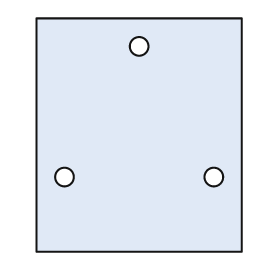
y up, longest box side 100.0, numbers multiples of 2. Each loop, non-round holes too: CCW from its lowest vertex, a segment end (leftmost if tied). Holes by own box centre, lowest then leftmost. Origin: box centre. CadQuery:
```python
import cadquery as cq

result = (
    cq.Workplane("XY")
    .moveTo(-44.0, -50.0)
    .lineTo(44.0, -50.0)
    .lineTo(44.0, 50.0)
    .lineTo(-44.0, 50.0)
    .close()
    .moveTo(-32.0, -18.0)
    .circle(4.0)
    .moveTo(32.0, -18.0)
    .circle(4.0)
    .moveTo(0.0, 38.0)
    .circle(4.0)
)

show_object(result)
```